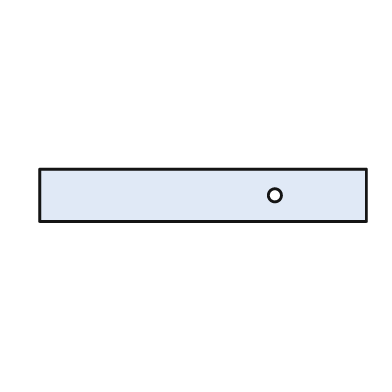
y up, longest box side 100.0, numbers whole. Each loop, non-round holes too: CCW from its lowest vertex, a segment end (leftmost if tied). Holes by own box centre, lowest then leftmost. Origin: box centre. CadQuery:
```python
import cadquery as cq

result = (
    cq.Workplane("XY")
    .moveTo(-50.0, -8.0)
    .lineTo(50.0, -8.0)
    .lineTo(50.0, 8.0)
    .lineTo(-50.0, 8.0)
    .close()
    .moveTo(22.0, 0.0)
    .circle(2.0)
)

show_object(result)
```